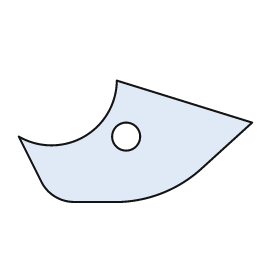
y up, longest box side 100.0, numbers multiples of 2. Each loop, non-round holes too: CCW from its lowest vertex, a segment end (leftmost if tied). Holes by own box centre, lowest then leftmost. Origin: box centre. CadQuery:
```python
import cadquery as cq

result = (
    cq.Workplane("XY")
    .moveTo(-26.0, -26.0)
    .lineTo(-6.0, -26.0)
    .threePointArc((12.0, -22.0), (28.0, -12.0))
    .lineTo(50.0, 8.0)
    .lineTo(-8.0, 26.0)
    .threePointArc((-22.0, 2.0), (-50.0, 2.0))
    .lineTo(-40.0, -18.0)
    .threePointArc((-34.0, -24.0), (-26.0, -26.0))
    .close()
    .moveTo(-4.0, 2.0)
    .circle(6.0)
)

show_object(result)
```